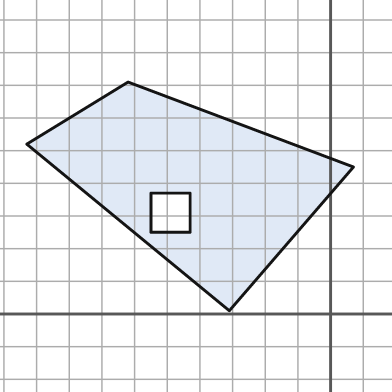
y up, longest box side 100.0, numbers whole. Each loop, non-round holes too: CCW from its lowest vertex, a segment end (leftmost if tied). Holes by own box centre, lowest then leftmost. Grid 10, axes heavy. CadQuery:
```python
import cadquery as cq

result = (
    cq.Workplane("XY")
    .moveTo(-31.0, 1.0)
    .lineTo(7.0, 45.0)
    .lineTo(-62.0, 71.0)
    .lineTo(-93.0, 52.0)
    .close()
    .moveTo(-55.0, 25.0)
    .lineTo(-43.0, 25.0)
    .lineTo(-43.0, 37.0)
    .lineTo(-55.0, 37.0)
    .close()
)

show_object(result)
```